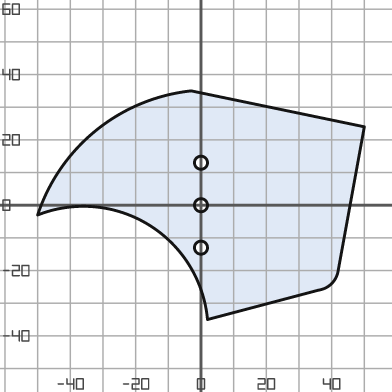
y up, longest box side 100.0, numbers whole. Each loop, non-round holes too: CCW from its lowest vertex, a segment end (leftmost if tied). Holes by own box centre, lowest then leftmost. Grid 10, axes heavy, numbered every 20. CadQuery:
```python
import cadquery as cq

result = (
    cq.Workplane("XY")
    .moveTo(2.0, -35.0)
    .lineTo(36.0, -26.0)
    .threePointArc((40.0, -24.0), (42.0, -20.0))
    .lineTo(50.0, 24.0)
    .lineTo(-3.0, 35.0)
    .threePointArc((-32.0, 23.0), (-50.0, -3.0))
    .threePointArc((-16.0, -6.0), (2.0, -35.0))
    .close()
    .moveTo(0.0, -13.0)
    .circle(2.0)
    .moveTo(0.0, 0.0)
    .circle(2.0)
    .moveTo(0.0, 13.0)
    .circle(2.0)
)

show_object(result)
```